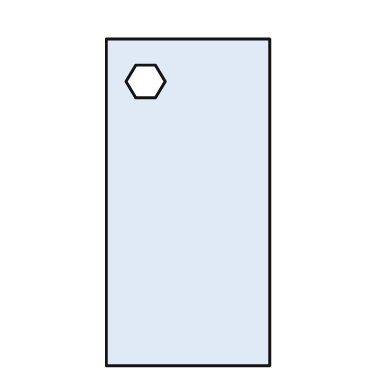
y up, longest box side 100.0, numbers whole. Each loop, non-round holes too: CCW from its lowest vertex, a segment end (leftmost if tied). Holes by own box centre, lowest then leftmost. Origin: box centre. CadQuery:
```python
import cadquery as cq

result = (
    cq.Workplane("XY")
    .moveTo(-25.0, -50.0)
    .lineTo(25.0, -50.0)
    .lineTo(25.0, 50.0)
    .lineTo(-25.0, 50.0)
    .close()
    .moveTo(-16.0, 32.0)
    .lineTo(-10.0, 32.0)
    .lineTo(-7.0, 37.0)
    .lineTo(-10.0, 42.0)
    .lineTo(-16.0, 42.0)
    .lineTo(-19.0, 37.0)
    .close()
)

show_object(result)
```